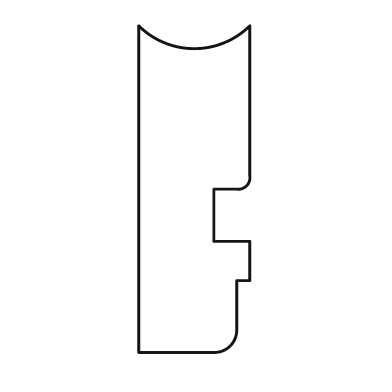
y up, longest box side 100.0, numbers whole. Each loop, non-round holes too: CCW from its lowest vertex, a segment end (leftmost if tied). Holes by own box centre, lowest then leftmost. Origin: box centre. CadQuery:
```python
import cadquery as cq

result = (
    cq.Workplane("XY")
    .moveTo(-17.0, -50.0)
    .lineTo(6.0, -50.0)
    .threePointArc((11.0, -48.0), (13.0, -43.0))
    .lineTo(13.0, -28.0)
    .lineTo(17.0, -28.0)
    .lineTo(17.0, -16.0)
    .lineTo(6.0, -16.0)
    .lineTo(6.0, 0.0)
    .lineTo(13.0, 0.0)
    .threePointArc((16.0, 1.0), (17.0, 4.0))
    .lineTo(17.0, 50.0)
    .threePointArc((0.0, 43.0), (-17.0, 50.0))
    .close()
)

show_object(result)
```